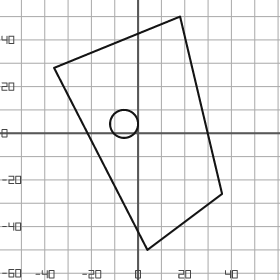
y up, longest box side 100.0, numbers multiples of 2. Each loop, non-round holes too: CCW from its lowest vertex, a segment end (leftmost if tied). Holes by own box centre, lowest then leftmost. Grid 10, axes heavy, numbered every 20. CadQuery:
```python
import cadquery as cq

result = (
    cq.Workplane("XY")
    .moveTo(4.0, -50.0)
    .lineTo(36.0, -26.0)
    .lineTo(18.0, 50.0)
    .lineTo(-36.0, 28.0)
    .close()
    .moveTo(-6.0, 4.0)
    .circle(6.0)
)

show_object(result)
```